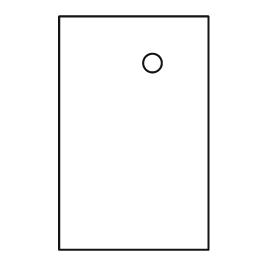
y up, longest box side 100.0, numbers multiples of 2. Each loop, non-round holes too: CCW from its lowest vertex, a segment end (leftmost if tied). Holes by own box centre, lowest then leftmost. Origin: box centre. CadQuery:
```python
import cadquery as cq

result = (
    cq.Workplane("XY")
    .moveTo(-32.0, -50.0)
    .lineTo(32.0, -50.0)
    .lineTo(32.0, 50.0)
    .lineTo(-32.0, 50.0)
    .close()
    .moveTo(8.0, 30.0)
    .circle(4.0)
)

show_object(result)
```